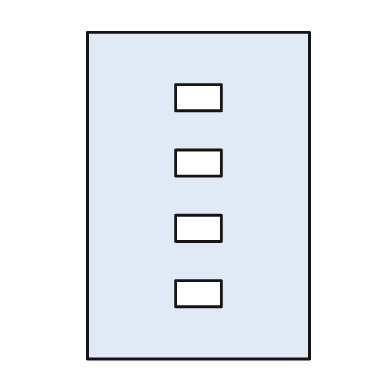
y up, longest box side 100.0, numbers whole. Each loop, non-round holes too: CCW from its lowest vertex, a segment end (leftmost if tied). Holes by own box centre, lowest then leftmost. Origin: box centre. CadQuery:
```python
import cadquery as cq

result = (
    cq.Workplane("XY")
    .moveTo(-34.0, -50.0)
    .lineTo(34.0, -50.0)
    .lineTo(34.0, 50.0)
    .lineTo(-34.0, 50.0)
    .close()
    .moveTo(-7.0, -34.0)
    .lineTo(7.0, -34.0)
    .lineTo(7.0, -26.0)
    .lineTo(-7.0, -26.0)
    .close()
    .moveTo(-7.0, -14.0)
    .lineTo(7.0, -14.0)
    .lineTo(7.0, -6.0)
    .lineTo(-7.0, -6.0)
    .close()
    .moveTo(-7.0, 6.0)
    .lineTo(7.0, 6.0)
    .lineTo(7.0, 14.0)
    .lineTo(-7.0, 14.0)
    .close()
    .moveTo(-7.0, 26.0)
    .lineTo(7.0, 26.0)
    .lineTo(7.0, 34.0)
    .lineTo(-7.0, 34.0)
    .close()
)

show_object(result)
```